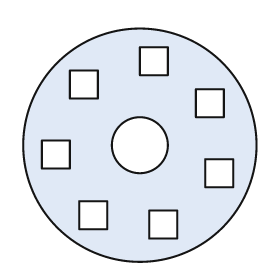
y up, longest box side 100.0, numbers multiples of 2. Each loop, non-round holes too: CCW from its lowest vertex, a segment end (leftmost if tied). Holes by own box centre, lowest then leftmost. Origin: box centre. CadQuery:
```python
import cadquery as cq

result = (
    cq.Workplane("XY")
    .moveTo(0.0, 0.0)
    .circle(50.0)
    .moveTo(4.0, -40.0)
    .lineTo(16.0, -40.0)
    .lineTo(16.0, -28.0)
    .lineTo(4.0, -28.0)
    .close()
    .moveTo(-26.0, -36.0)
    .lineTo(-14.0, -36.0)
    .lineTo(-14.0, -24.0)
    .lineTo(-26.0, -24.0)
    .close()
    .moveTo(28.0, -18.0)
    .lineTo(40.0, -18.0)
    .lineTo(40.0, -6.0)
    .lineTo(28.0, -6.0)
    .close()
    .moveTo(-42.0, -10.0)
    .lineTo(-30.0, -10.0)
    .lineTo(-30.0, 2.0)
    .lineTo(-42.0, 2.0)
    .close()
    .moveTo(0.0, 0.0)
    .circle(12.0)
    .moveTo(24.0, 12.0)
    .lineTo(36.0, 12.0)
    .lineTo(36.0, 24.0)
    .lineTo(24.0, 24.0)
    .close()
    .moveTo(-30.0, 20.0)
    .lineTo(-18.0, 20.0)
    .lineTo(-18.0, 32.0)
    .lineTo(-30.0, 32.0)
    .close()
    .moveTo(0.0, 30.0)
    .lineTo(12.0, 30.0)
    .lineTo(12.0, 42.0)
    .lineTo(0.0, 42.0)
    .close()
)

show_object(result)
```